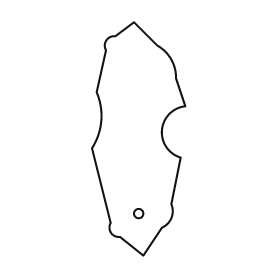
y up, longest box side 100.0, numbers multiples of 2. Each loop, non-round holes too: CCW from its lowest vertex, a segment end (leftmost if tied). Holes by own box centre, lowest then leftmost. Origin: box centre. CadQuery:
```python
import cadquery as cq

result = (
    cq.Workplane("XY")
    .moveTo(2.0, -50.0)
    .lineTo(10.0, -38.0)
    .threePointArc((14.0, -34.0), (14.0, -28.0))
    .lineTo(18.0, -8.0)
    .threePointArc((10.0, 4.0), (20.0, 14.0))
    .lineTo(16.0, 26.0)
    .threePointArc((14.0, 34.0), (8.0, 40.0))
    .lineTo(-2.0, 50.0)
    .lineTo(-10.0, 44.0)
    .threePointArc((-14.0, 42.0), (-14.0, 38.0))
    .lineTo(-18.0, 20.0)
    .threePointArc((-16.0, 8.0), (-20.0, -4.0))
    .lineTo(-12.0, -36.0)
    .threePointArc((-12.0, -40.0), (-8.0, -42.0))
    .close()
    .moveTo(0.0, -32.0)
    .circle(2.0)
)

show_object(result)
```